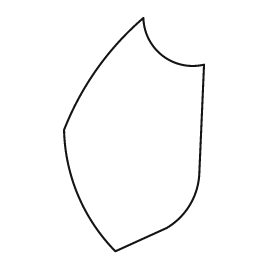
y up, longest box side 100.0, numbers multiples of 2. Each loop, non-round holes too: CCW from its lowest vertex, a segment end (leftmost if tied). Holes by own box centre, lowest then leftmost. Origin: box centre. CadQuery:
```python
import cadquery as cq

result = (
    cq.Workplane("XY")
    .moveTo(-8.0, -50.0)
    .lineTo(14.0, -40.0)
    .threePointArc((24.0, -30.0), (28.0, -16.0))
    .lineTo(30.0, 30.0)
    .threePointArc((12.0, 34.0), (4.0, 50.0))
    .threePointArc((-16.0, 28.0), (-30.0, 2.0))
    .threePointArc((-24.0, -26.0), (-8.0, -50.0))
    .close()
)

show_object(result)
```